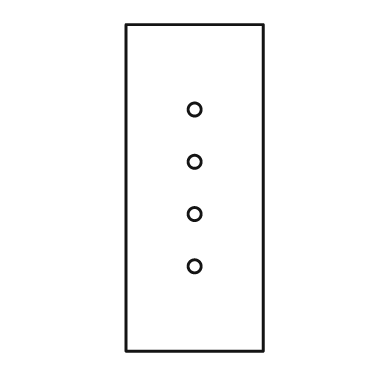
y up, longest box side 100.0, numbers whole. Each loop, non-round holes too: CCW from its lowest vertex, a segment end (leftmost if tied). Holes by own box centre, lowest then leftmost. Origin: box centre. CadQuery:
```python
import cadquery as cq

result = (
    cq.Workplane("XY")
    .moveTo(-21.0, -50.0)
    .lineTo(21.0, -50.0)
    .lineTo(21.0, 50.0)
    .lineTo(-21.0, 50.0)
    .close()
    .moveTo(0.0, -24.0)
    .circle(2.0)
    .moveTo(0.0, -8.0)
    .circle(2.0)
    .moveTo(0.0, 8.0)
    .circle(2.0)
    .moveTo(0.0, 24.0)
    .circle(2.0)
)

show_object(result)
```